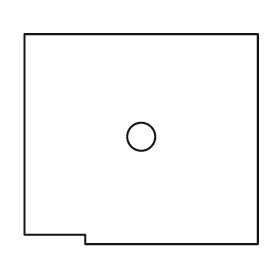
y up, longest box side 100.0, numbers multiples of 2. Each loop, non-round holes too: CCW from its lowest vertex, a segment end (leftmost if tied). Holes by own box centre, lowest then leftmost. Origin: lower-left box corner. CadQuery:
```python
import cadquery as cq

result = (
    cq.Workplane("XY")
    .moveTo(26.0, 0.0)
    .lineTo(100.0, 0.0)
    .lineTo(100.0, 90.0)
    .lineTo(0.0, 90.0)
    .lineTo(0.0, 4.0)
    .lineTo(26.0, 4.0)
    .close()
    .moveTo(50.0, 46.0)
    .circle(6.0)
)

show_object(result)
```